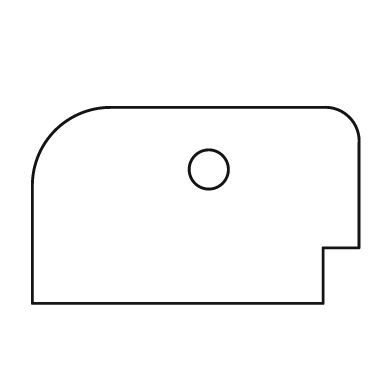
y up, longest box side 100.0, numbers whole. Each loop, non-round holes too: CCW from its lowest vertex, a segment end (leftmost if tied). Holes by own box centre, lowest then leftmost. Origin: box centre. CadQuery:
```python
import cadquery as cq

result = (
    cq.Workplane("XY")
    .moveTo(-50.0, -30.0)
    .lineTo(39.0, -30.0)
    .lineTo(39.0, -13.0)
    .lineTo(50.0, -13.0)
    .lineTo(50.0, 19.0)
    .threePointArc((47.0, 27.0), (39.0, 30.0))
    .lineTo(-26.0, 30.0)
    .threePointArc((-43.0, 23.0), (-50.0, 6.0))
    .close()
    .moveTo(4.0, 11.0)
    .circle(6.0)
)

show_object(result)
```